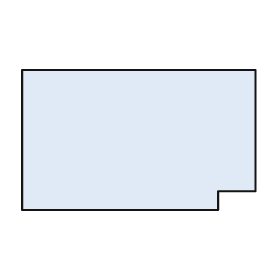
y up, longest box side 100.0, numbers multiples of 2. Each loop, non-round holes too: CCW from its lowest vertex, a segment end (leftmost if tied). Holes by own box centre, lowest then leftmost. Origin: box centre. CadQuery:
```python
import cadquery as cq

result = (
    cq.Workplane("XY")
    .moveTo(-50.0, -30.0)
    .lineTo(34.0, -30.0)
    .lineTo(34.0, -22.0)
    .lineTo(50.0, -22.0)
    .lineTo(50.0, 30.0)
    .lineTo(-50.0, 30.0)
    .close()
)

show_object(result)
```